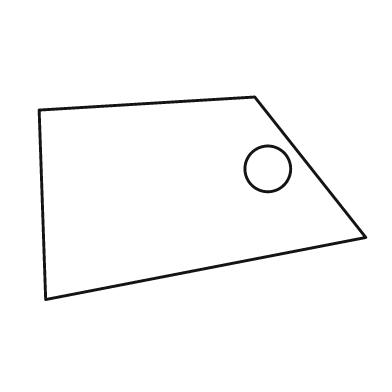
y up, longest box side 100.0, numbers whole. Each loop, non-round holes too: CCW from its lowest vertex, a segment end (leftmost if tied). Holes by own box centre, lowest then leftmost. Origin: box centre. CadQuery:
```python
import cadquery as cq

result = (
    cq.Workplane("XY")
    .moveTo(-48.0, -31.0)
    .lineTo(50.0, -12.0)
    .lineTo(16.0, 31.0)
    .lineTo(-50.0, 27.0)
    .close()
    .moveTo(20.0, 9.0)
    .circle(7.0)
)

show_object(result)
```